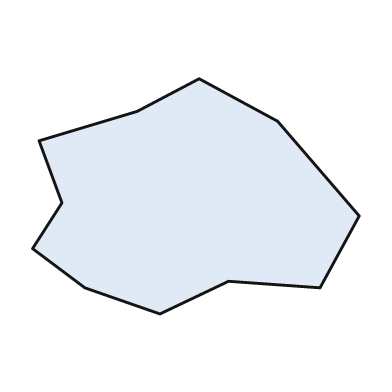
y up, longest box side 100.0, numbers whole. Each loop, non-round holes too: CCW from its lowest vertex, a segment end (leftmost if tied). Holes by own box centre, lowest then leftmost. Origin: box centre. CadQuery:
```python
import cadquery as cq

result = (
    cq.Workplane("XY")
    .moveTo(-11.0, -36.0)
    .lineTo(10.0, -26.0)
    .lineTo(38.0, -28.0)
    .lineTo(50.0, -6.0)
    .lineTo(25.0, 23.0)
    .lineTo(1.0, 36.0)
    .lineTo(-18.0, 26.0)
    .lineTo(-48.0, 17.0)
    .lineTo(-41.0, -2.0)
    .lineTo(-50.0, -16.0)
    .lineTo(-34.0, -28.0)
    .close()
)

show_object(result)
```